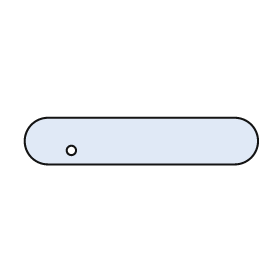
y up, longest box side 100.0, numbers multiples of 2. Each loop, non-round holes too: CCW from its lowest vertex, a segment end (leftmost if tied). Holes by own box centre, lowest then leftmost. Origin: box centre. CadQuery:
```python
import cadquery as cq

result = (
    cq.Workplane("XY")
    .moveTo(-40.0, -10.0)
    .lineTo(40.0, -10.0)
    .threePointArc((50.0, 0.0), (40.0, 10.0))
    .lineTo(-40.0, 10.0)
    .threePointArc((-50.0, 0.0), (-40.0, -10.0))
    .close()
    .moveTo(-30.0, -4.0)
    .circle(2.0)
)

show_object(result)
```